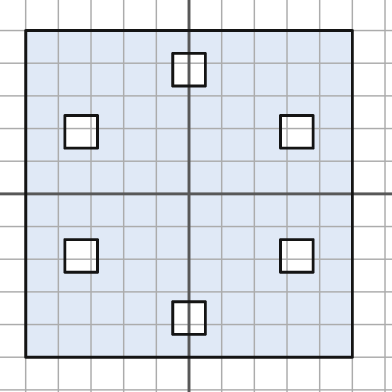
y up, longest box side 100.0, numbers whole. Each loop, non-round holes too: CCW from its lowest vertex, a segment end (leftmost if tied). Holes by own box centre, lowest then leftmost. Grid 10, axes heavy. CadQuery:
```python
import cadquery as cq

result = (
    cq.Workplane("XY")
    .moveTo(-50.0, -50.0)
    .lineTo(50.0, -50.0)
    .lineTo(50.0, 50.0)
    .lineTo(-50.0, 50.0)
    .close()
    .moveTo(-5.0, -43.0)
    .lineTo(5.0, -43.0)
    .lineTo(5.0, -33.0)
    .lineTo(-5.0, -33.0)
    .close()
    .moveTo(-38.0, -24.0)
    .lineTo(-28.0, -24.0)
    .lineTo(-28.0, -14.0)
    .lineTo(-38.0, -14.0)
    .close()
    .moveTo(28.0, -24.0)
    .lineTo(38.0, -24.0)
    .lineTo(38.0, -14.0)
    .lineTo(28.0, -14.0)
    .close()
    .moveTo(-38.0, 14.0)
    .lineTo(-28.0, 14.0)
    .lineTo(-28.0, 24.0)
    .lineTo(-38.0, 24.0)
    .close()
    .moveTo(28.0, 14.0)
    .lineTo(38.0, 14.0)
    .lineTo(38.0, 24.0)
    .lineTo(28.0, 24.0)
    .close()
    .moveTo(-5.0, 33.0)
    .lineTo(5.0, 33.0)
    .lineTo(5.0, 43.0)
    .lineTo(-5.0, 43.0)
    .close()
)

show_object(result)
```